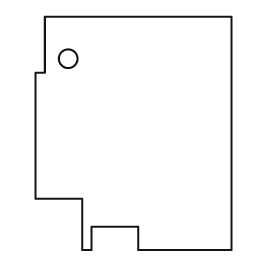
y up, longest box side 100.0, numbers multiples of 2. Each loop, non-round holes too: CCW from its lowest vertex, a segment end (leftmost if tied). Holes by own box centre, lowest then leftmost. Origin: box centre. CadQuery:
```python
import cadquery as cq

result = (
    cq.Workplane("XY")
    .moveTo(-22.0, -50.0)
    .lineTo(-18.0, -50.0)
    .lineTo(-18.0, -40.0)
    .lineTo(2.0, -40.0)
    .lineTo(2.0, -50.0)
    .lineTo(42.0, -50.0)
    .lineTo(42.0, 50.0)
    .lineTo(-38.0, 50.0)
    .lineTo(-38.0, 26.0)
    .lineTo(-42.0, 26.0)
    .lineTo(-42.0, -28.0)
    .lineTo(-22.0, -28.0)
    .close()
    .moveTo(-28.0, 32.0)
    .circle(4.0)
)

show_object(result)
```